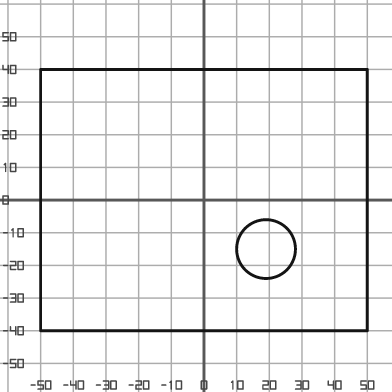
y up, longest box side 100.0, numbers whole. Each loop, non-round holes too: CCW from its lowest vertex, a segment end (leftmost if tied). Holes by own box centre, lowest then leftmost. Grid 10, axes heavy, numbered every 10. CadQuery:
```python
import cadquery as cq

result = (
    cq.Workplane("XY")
    .moveTo(-50.0, -40.0)
    .lineTo(50.0, -40.0)
    .lineTo(50.0, 40.0)
    .lineTo(-50.0, 40.0)
    .close()
    .moveTo(19.0, -15.0)
    .circle(9.0)
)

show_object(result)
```